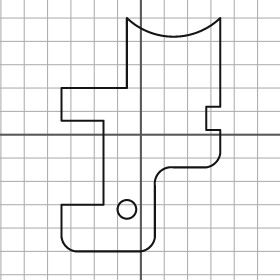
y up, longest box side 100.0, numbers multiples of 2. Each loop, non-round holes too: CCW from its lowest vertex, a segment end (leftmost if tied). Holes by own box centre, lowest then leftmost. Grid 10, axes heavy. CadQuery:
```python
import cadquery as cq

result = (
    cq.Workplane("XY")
    .moveTo(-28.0, -50.0)
    .lineTo(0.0, -50.0)
    .threePointArc((4.0, -48.0), (6.0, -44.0))
    .lineTo(6.0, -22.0)
    .threePointArc((8.0, -16.0), (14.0, -14.0))
    .lineTo(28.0, -14.0)
    .threePointArc((32.0, -12.0), (34.0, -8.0))
    .lineTo(34.0, 2.0)
    .lineTo(28.0, 2.0)
    .lineTo(28.0, 12.0)
    .lineTo(34.0, 12.0)
    .lineTo(34.0, 50.0)
    .threePointArc((14.0, 42.0), (-6.0, 50.0))
    .lineTo(-6.0, 20.0)
    .lineTo(-34.0, 20.0)
    .lineTo(-34.0, 6.0)
    .lineTo(-16.0, 6.0)
    .lineTo(-16.0, -30.0)
    .lineTo(-34.0, -30.0)
    .lineTo(-34.0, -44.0)
    .threePointArc((-32.0, -48.0), (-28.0, -50.0))
    .close()
    .moveTo(-6.0, -32.0)
    .circle(4.0)
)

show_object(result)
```